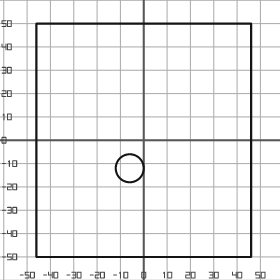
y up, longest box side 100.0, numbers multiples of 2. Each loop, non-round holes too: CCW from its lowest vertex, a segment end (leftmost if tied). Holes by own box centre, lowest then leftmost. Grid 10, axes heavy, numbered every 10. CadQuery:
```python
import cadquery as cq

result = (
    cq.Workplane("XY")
    .moveTo(-46.0, -50.0)
    .lineTo(46.0, -50.0)
    .lineTo(46.0, 50.0)
    .lineTo(-46.0, 50.0)
    .close()
    .moveTo(-6.0, -12.0)
    .circle(6.0)
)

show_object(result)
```